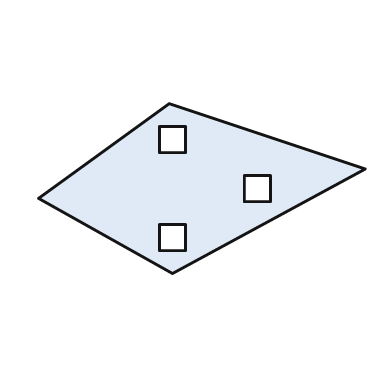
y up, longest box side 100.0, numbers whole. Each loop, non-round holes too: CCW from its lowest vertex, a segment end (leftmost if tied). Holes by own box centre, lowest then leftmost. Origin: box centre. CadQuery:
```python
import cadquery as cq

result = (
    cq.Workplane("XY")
    .moveTo(-9.0, -26.0)
    .lineTo(50.0, 6.0)
    .lineTo(-10.0, 26.0)
    .lineTo(-50.0, -3.0)
    .close()
    .moveTo(-13.0, -19.0)
    .lineTo(-5.0, -19.0)
    .lineTo(-5.0, -11.0)
    .lineTo(-13.0, -11.0)
    .close()
    .moveTo(13.0, -4.0)
    .lineTo(21.0, -4.0)
    .lineTo(21.0, 4.0)
    .lineTo(13.0, 4.0)
    .close()
    .moveTo(-13.0, 11.0)
    .lineTo(-5.0, 11.0)
    .lineTo(-5.0, 19.0)
    .lineTo(-13.0, 19.0)
    .close()
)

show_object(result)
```